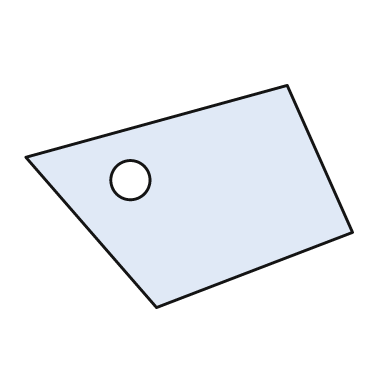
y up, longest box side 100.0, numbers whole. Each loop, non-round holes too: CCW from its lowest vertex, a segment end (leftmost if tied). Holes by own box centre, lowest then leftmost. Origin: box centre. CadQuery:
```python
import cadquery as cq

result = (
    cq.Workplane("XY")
    .moveTo(-10.0, -34.0)
    .lineTo(50.0, -11.0)
    .lineTo(30.0, 34.0)
    .lineTo(-50.0, 12.0)
    .close()
    .moveTo(-18.0, 5.0)
    .circle(6.0)
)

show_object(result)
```